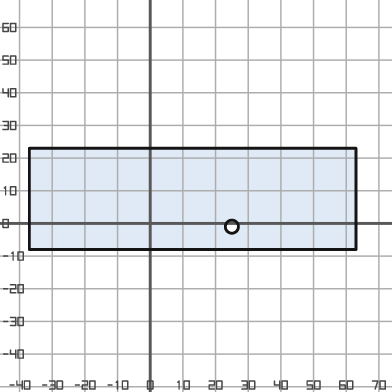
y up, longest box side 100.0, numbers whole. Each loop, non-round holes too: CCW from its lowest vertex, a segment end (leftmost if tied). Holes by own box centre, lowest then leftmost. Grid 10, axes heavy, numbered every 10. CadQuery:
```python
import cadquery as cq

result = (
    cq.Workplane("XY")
    .moveTo(-37.0, -8.0)
    .lineTo(63.0, -8.0)
    .lineTo(63.0, 23.0)
    .lineTo(-37.0, 23.0)
    .close()
    .moveTo(25.0, -1.0)
    .circle(2.0)
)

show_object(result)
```